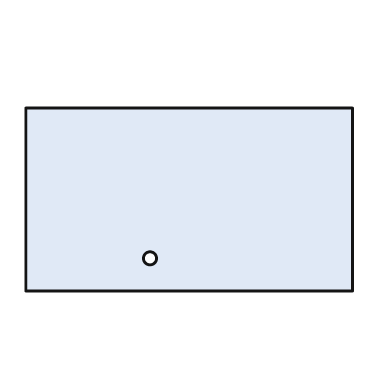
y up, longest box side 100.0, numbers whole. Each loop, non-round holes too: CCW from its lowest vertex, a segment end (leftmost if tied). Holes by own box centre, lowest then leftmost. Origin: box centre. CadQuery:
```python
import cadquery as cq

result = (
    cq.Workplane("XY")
    .moveTo(-50.0, -28.0)
    .lineTo(50.0, -28.0)
    .lineTo(50.0, 28.0)
    .lineTo(-50.0, 28.0)
    .close()
    .moveTo(-12.0, -18.0)
    .circle(2.0)
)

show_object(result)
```